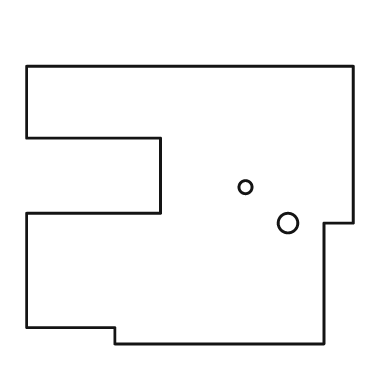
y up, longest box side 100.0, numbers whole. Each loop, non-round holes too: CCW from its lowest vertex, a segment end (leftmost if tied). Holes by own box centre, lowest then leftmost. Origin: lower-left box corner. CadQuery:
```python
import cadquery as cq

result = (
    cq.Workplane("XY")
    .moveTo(27.0, 0.0)
    .lineTo(91.0, 0.0)
    .lineTo(91.0, 37.0)
    .lineTo(100.0, 37.0)
    .lineTo(100.0, 85.0)
    .lineTo(0.0, 85.0)
    .lineTo(0.0, 63.0)
    .lineTo(41.0, 63.0)
    .lineTo(41.0, 40.0)
    .lineTo(0.0, 40.0)
    .lineTo(0.0, 5.0)
    .lineTo(27.0, 5.0)
    .close()
    .moveTo(80.0, 37.0)
    .circle(3.0)
    .moveTo(67.0, 48.0)
    .circle(2.0)
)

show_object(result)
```